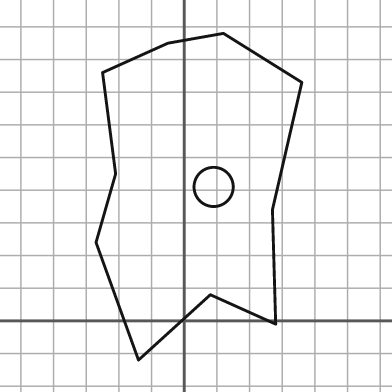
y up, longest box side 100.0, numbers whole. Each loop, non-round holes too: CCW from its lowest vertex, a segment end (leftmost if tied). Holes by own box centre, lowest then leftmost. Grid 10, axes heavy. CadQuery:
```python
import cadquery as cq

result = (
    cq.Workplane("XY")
    .moveTo(-14.0, -12.0)
    .lineTo(8.0, 8.0)
    .lineTo(28.0, -1.0)
    .lineTo(27.0, 34.0)
    .lineTo(36.0, 73.0)
    .lineTo(12.0, 88.0)
    .lineTo(-5.0, 85.0)
    .lineTo(-25.0, 76.0)
    .lineTo(-21.0, 45.0)
    .lineTo(-27.0, 24.0)
    .close()
    .moveTo(9.0, 41.0)
    .circle(6.0)
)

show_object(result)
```